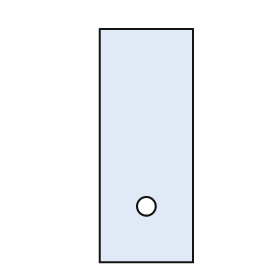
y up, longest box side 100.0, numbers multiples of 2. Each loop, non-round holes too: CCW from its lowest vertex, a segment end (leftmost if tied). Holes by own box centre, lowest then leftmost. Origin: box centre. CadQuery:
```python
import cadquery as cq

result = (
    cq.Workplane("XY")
    .moveTo(-20.0, -50.0)
    .lineTo(20.0, -50.0)
    .lineTo(20.0, 50.0)
    .lineTo(-20.0, 50.0)
    .close()
    .moveTo(0.0, -26.0)
    .circle(4.0)
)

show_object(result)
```